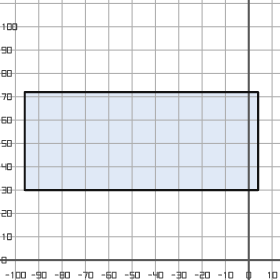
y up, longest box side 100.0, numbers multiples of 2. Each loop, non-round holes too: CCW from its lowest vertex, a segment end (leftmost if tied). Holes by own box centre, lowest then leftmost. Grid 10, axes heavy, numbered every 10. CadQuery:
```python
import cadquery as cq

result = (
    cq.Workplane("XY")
    .moveTo(-96.0, 30.0)
    .lineTo(4.0, 30.0)
    .lineTo(4.0, 72.0)
    .lineTo(-96.0, 72.0)
    .close()
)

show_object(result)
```